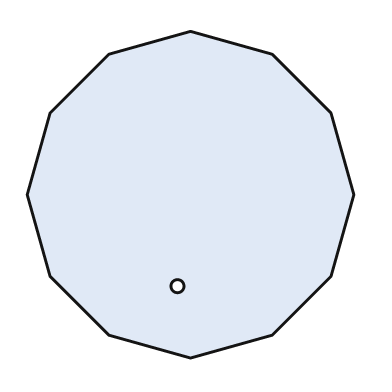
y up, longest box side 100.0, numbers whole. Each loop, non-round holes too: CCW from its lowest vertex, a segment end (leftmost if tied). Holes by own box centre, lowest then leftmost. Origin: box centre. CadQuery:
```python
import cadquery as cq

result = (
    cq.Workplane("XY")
    .moveTo(0.0, -50.0)
    .lineTo(25.0, -43.0)
    .lineTo(43.0, -25.0)
    .lineTo(50.0, 0.0)
    .lineTo(43.0, 25.0)
    .lineTo(25.0, 43.0)
    .lineTo(0.0, 50.0)
    .lineTo(-25.0, 43.0)
    .lineTo(-43.0, 25.0)
    .lineTo(-50.0, 0.0)
    .lineTo(-43.0, -25.0)
    .lineTo(-25.0, -43.0)
    .close()
    .moveTo(-4.0, -28.0)
    .circle(2.0)
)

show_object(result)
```